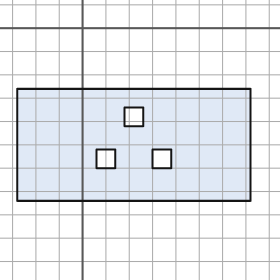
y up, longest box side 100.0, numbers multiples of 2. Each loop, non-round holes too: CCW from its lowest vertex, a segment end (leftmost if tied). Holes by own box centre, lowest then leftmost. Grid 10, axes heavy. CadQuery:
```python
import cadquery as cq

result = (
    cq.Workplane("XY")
    .moveTo(-28.0, -74.0)
    .lineTo(72.0, -74.0)
    .lineTo(72.0, -26.0)
    .lineTo(-28.0, -26.0)
    .close()
    .moveTo(6.0, -60.0)
    .lineTo(14.0, -60.0)
    .lineTo(14.0, -52.0)
    .lineTo(6.0, -52.0)
    .close()
    .moveTo(30.0, -60.0)
    .lineTo(38.0, -60.0)
    .lineTo(38.0, -52.0)
    .lineTo(30.0, -52.0)
    .close()
    .moveTo(18.0, -42.0)
    .lineTo(26.0, -42.0)
    .lineTo(26.0, -34.0)
    .lineTo(18.0, -34.0)
    .close()
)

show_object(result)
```